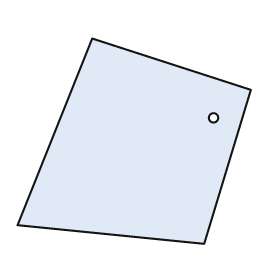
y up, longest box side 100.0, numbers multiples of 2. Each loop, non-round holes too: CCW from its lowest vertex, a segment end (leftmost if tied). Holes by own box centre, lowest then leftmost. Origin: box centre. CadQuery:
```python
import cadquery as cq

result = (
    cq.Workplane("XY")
    .moveTo(30.0, -44.0)
    .lineTo(50.0, 22.0)
    .lineTo(-18.0, 44.0)
    .lineTo(-50.0, -36.0)
    .close()
    .moveTo(34.0, 10.0)
    .circle(2.0)
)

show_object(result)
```